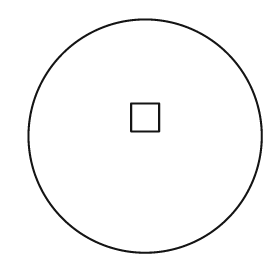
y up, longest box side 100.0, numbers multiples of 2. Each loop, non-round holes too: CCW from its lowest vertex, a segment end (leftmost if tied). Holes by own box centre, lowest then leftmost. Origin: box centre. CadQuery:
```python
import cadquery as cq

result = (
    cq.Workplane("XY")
    .moveTo(0.0, 0.0)
    .circle(50.0)
    .moveTo(-6.0, 2.0)
    .lineTo(6.0, 2.0)
    .lineTo(6.0, 14.0)
    .lineTo(-6.0, 14.0)
    .close()
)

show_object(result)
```